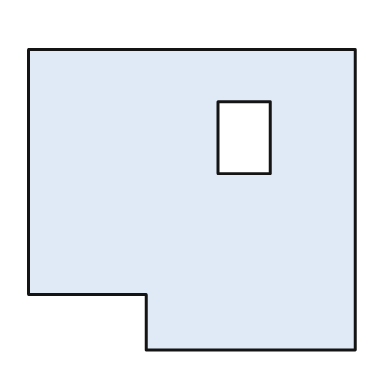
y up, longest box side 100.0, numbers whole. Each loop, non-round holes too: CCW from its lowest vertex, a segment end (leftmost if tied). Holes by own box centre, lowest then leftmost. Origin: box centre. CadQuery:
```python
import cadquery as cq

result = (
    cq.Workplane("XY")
    .moveTo(-14.0, -46.0)
    .lineTo(50.0, -46.0)
    .lineTo(50.0, 46.0)
    .lineTo(-50.0, 46.0)
    .lineTo(-50.0, -29.0)
    .lineTo(-14.0, -29.0)
    .close()
    .moveTo(8.0, 8.0)
    .lineTo(24.0, 8.0)
    .lineTo(24.0, 30.0)
    .lineTo(8.0, 30.0)
    .close()
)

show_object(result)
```